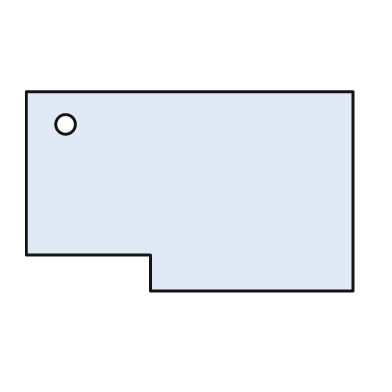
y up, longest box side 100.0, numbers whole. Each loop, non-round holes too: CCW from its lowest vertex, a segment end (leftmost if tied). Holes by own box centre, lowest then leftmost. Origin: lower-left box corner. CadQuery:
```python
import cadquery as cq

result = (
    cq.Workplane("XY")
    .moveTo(38.0, 0.0)
    .lineTo(100.0, 0.0)
    .lineTo(100.0, 61.0)
    .lineTo(0.0, 61.0)
    .lineTo(0.0, 11.0)
    .lineTo(38.0, 11.0)
    .close()
    .moveTo(12.0, 51.0)
    .circle(3.0)
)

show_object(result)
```